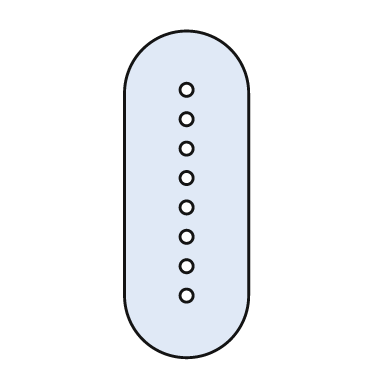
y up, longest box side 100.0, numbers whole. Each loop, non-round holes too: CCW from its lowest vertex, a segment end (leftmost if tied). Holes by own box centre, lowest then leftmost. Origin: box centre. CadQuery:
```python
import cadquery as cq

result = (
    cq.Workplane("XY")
    .moveTo(-19.0, -31.0)
    .threePointArc((0.0, -50.0), (19.0, -31.0))
    .lineTo(19.0, 31.0)
    .threePointArc((0.0, 50.0), (-19.0, 31.0))
    .close()
    .moveTo(0.0, -31.0)
    .circle(2.0)
    .moveTo(0.0, -22.0)
    .circle(2.0)
    .moveTo(0.0, -13.0)
    .circle(2.0)
    .moveTo(0.0, -4.0)
    .circle(2.0)
    .moveTo(0.0, 5.0)
    .circle(2.0)
    .moveTo(0.0, 14.0)
    .circle(2.0)
    .moveTo(0.0, 23.0)
    .circle(2.0)
    .moveTo(0.0, 32.0)
    .circle(2.0)
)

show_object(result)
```